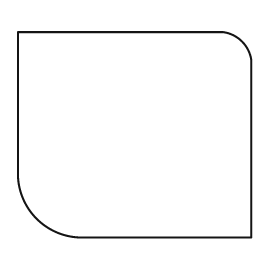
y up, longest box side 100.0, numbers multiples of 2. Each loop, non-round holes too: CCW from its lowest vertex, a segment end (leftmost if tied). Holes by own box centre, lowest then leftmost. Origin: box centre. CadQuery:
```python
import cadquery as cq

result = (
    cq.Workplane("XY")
    .moveTo(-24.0, -44.0)
    .lineTo(50.0, -44.0)
    .lineTo(50.0, 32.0)
    .threePointArc((46.0, 40.0), (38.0, 44.0))
    .lineTo(-50.0, 44.0)
    .lineTo(-50.0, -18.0)
    .threePointArc((-42.0, -36.0), (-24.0, -44.0))
    .close()
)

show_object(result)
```